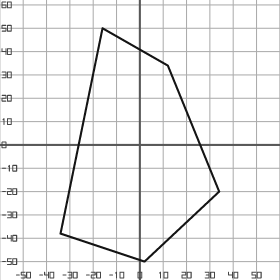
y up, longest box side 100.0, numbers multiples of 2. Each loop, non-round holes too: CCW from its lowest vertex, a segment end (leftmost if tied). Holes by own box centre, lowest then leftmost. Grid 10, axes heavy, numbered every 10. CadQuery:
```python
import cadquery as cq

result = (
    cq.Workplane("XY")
    .moveTo(2.0, -50.0)
    .lineTo(34.0, -20.0)
    .lineTo(12.0, 34.0)
    .lineTo(-16.0, 50.0)
    .lineTo(-34.0, -38.0)
    .close()
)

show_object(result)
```